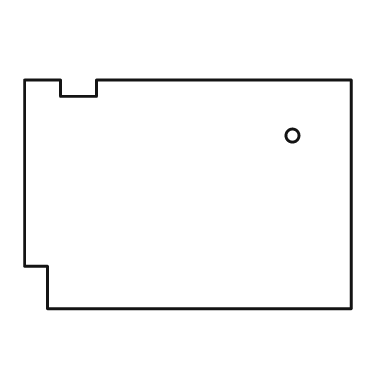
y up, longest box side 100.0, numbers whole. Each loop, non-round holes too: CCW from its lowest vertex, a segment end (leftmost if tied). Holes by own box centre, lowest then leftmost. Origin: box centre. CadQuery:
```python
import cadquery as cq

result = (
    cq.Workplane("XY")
    .moveTo(-43.0, -35.0)
    .lineTo(50.0, -35.0)
    .lineTo(50.0, 35.0)
    .lineTo(-28.0, 35.0)
    .lineTo(-28.0, 30.0)
    .lineTo(-39.0, 30.0)
    .lineTo(-39.0, 35.0)
    .lineTo(-50.0, 35.0)
    .lineTo(-50.0, -22.0)
    .lineTo(-43.0, -22.0)
    .close()
    .moveTo(32.0, 18.0)
    .circle(2.0)
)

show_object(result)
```